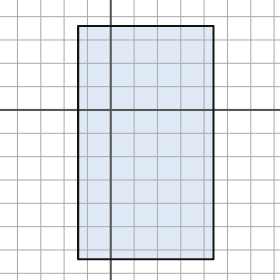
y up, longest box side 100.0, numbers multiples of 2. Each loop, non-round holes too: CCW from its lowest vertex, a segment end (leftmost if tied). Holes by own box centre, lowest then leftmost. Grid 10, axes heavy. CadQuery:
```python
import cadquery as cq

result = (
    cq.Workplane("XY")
    .moveTo(-14.0, -64.0)
    .lineTo(44.0, -64.0)
    .lineTo(44.0, 36.0)
    .lineTo(-14.0, 36.0)
    .close()
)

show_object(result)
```